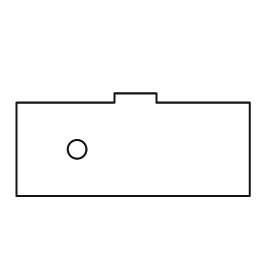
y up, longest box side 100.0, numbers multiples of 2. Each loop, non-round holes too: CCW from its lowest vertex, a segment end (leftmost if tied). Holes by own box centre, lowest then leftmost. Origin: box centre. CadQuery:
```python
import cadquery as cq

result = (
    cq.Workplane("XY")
    .moveTo(-50.0, -22.0)
    .lineTo(50.0, -22.0)
    .lineTo(50.0, 18.0)
    .lineTo(10.0, 18.0)
    .lineTo(10.0, 22.0)
    .lineTo(-8.0, 22.0)
    .lineTo(-8.0, 18.0)
    .lineTo(-50.0, 18.0)
    .close()
    .moveTo(-24.0, -2.0)
    .circle(4.0)
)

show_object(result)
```